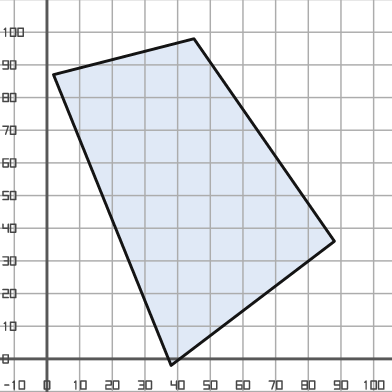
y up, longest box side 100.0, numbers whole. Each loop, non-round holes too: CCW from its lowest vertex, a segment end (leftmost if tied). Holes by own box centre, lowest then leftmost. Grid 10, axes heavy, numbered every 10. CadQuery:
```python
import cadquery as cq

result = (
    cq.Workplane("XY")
    .moveTo(38.0, -2.0)
    .lineTo(88.0, 36.0)
    .lineTo(45.0, 98.0)
    .lineTo(2.0, 87.0)
    .close()
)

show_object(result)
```